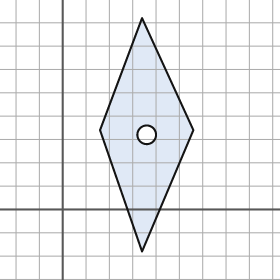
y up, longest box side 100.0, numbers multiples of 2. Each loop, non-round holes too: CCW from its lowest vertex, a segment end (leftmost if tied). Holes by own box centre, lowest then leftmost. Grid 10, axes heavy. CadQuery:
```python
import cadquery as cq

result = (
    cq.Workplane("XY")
    .moveTo(34.0, -18.0)
    .lineTo(56.0, 34.0)
    .lineTo(34.0, 82.0)
    .lineTo(16.0, 34.0)
    .close()
    .moveTo(36.0, 32.0)
    .circle(4.0)
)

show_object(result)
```